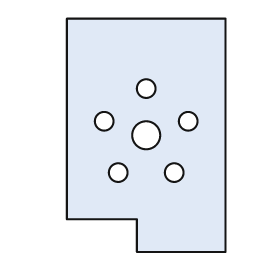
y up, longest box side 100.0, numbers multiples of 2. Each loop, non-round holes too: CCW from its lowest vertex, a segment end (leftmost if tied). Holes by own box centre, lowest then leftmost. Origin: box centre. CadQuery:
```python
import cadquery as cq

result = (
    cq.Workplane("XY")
    .moveTo(-4.0, -50.0)
    .lineTo(34.0, -50.0)
    .lineTo(34.0, 50.0)
    .lineTo(-34.0, 50.0)
    .lineTo(-34.0, -36.0)
    .lineTo(-4.0, -36.0)
    .close()
    .moveTo(-12.0, -16.0)
    .circle(4.0)
    .moveTo(12.0, -16.0)
    .circle(4.0)
    .moveTo(0.0, 0.0)
    .circle(6.0)
    .moveTo(-18.0, 6.0)
    .circle(4.0)
    .moveTo(18.0, 6.0)
    .circle(4.0)
    .moveTo(0.0, 20.0)
    .circle(4.0)
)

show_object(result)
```